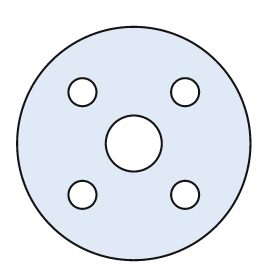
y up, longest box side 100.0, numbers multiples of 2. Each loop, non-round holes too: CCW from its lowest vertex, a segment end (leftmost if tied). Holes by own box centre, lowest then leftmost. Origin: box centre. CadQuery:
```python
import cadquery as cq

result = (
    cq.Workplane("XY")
    .moveTo(0.0, 0.0)
    .circle(50.0)
    .moveTo(-22.0, -22.0)
    .circle(6.0)
    .moveTo(22.0, -22.0)
    .circle(6.0)
    .moveTo(0.0, 0.0)
    .circle(12.0)
    .moveTo(-22.0, 22.0)
    .circle(6.0)
    .moveTo(22.0, 22.0)
    .circle(6.0)
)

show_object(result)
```